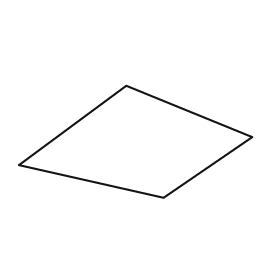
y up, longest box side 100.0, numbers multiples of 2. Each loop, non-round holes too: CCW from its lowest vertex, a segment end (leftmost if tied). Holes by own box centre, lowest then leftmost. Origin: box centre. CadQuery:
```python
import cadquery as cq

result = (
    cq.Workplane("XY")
    .moveTo(12.0, -24.0)
    .lineTo(50.0, 2.0)
    .lineTo(-4.0, 24.0)
    .lineTo(-50.0, -10.0)
    .close()
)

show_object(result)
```